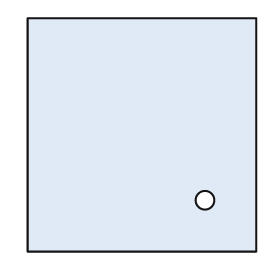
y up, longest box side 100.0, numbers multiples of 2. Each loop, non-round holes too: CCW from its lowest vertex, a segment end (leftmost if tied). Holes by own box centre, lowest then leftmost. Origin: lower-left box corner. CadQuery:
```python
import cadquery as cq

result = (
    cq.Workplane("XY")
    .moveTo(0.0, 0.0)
    .lineTo(98.0, 0.0)
    .lineTo(98.0, 100.0)
    .lineTo(0.0, 100.0)
    .close()
    .moveTo(76.0, 22.0)
    .circle(4.0)
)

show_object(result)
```